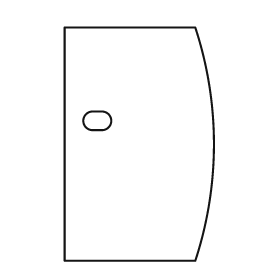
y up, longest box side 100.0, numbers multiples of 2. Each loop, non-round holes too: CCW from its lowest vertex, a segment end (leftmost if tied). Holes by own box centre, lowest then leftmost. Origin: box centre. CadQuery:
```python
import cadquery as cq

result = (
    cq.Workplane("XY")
    .moveTo(-32.0, -50.0)
    .lineTo(24.0, -50.0)
    .threePointArc((32.0, 0.0), (24.0, 50.0))
    .lineTo(-32.0, 50.0)
    .close()
    .moveTo(-20.0, 6.0)
    .lineTo(-16.0, 6.0)
    .threePointArc((-12.0, 10.0), (-16.0, 14.0))
    .lineTo(-20.0, 14.0)
    .threePointArc((-24.0, 10.0), (-20.0, 6.0))
    .close()
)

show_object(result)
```